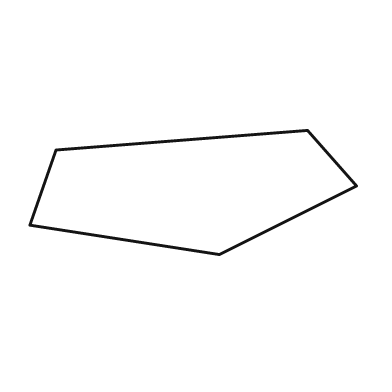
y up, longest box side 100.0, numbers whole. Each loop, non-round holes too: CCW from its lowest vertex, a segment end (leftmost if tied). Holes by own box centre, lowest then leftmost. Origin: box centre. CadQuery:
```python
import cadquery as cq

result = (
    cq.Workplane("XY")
    .moveTo(8.0, -19.0)
    .lineTo(50.0, 2.0)
    .lineTo(35.0, 19.0)
    .lineTo(-42.0, 13.0)
    .lineTo(-50.0, -10.0)
    .close()
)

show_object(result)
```